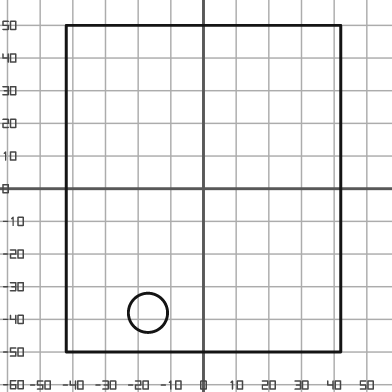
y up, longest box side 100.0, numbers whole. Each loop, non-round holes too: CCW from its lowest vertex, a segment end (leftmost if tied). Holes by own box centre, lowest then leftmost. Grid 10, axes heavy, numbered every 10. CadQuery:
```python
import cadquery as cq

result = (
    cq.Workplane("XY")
    .moveTo(-42.0, -50.0)
    .lineTo(42.0, -50.0)
    .lineTo(42.0, 50.0)
    .lineTo(-42.0, 50.0)
    .close()
    .moveTo(-17.0, -38.0)
    .circle(6.0)
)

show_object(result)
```